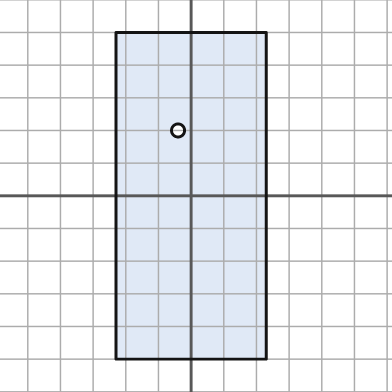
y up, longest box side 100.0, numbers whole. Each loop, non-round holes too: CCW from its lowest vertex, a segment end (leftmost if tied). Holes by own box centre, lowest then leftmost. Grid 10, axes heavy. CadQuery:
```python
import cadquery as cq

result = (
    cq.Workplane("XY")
    .moveTo(-23.0, -50.0)
    .lineTo(23.0, -50.0)
    .lineTo(23.0, 50.0)
    .lineTo(-23.0, 50.0)
    .close()
    .moveTo(-4.0, 20.0)
    .circle(2.0)
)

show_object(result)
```